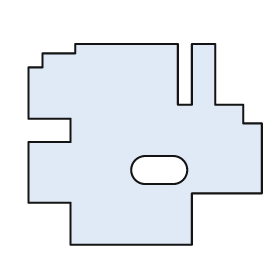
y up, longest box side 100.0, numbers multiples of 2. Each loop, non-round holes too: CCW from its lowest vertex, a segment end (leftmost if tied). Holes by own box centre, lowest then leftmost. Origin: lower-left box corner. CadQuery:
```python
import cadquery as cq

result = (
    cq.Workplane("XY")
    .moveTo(18.0, 0.0)
    .lineTo(70.0, 0.0)
    .lineTo(70.0, 22.0)
    .lineTo(100.0, 22.0)
    .lineTo(100.0, 52.0)
    .lineTo(92.0, 52.0)
    .lineTo(92.0, 60.0)
    .lineTo(80.0, 60.0)
    .lineTo(80.0, 86.0)
    .lineTo(70.0, 86.0)
    .lineTo(70.0, 60.0)
    .lineTo(64.0, 60.0)
    .lineTo(64.0, 86.0)
    .lineTo(20.0, 86.0)
    .lineTo(20.0, 82.0)
    .lineTo(6.0, 82.0)
    .lineTo(6.0, 76.0)
    .lineTo(0.0, 76.0)
    .lineTo(0.0, 54.0)
    .lineTo(18.0, 54.0)
    .lineTo(18.0, 44.0)
    .lineTo(0.0, 44.0)
    .lineTo(0.0, 18.0)
    .lineTo(18.0, 18.0)
    .close()
    .moveTo(50.0, 26.0)
    .lineTo(62.0, 26.0)
    .threePointArc((68.0, 32.0), (62.0, 38.0))
    .lineTo(50.0, 38.0)
    .threePointArc((44.0, 32.0), (50.0, 26.0))
    .close()
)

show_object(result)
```